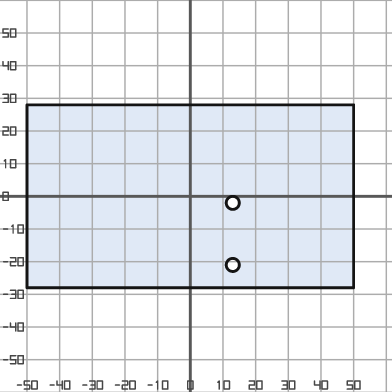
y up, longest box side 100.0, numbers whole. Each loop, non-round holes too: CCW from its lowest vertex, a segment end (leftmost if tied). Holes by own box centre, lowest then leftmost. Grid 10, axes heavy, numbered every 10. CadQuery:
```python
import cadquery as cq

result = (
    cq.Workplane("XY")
    .moveTo(-50.0, -28.0)
    .lineTo(50.0, -28.0)
    .lineTo(50.0, 28.0)
    .lineTo(-50.0, 28.0)
    .close()
    .moveTo(13.0, -21.0)
    .circle(2.0)
    .moveTo(13.0, -2.0)
    .circle(2.0)
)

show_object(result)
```